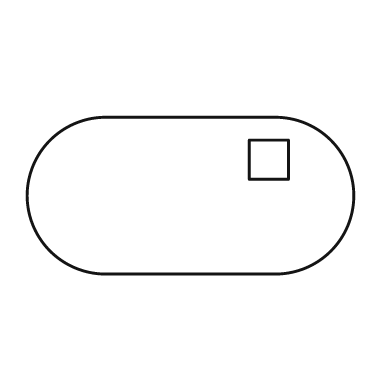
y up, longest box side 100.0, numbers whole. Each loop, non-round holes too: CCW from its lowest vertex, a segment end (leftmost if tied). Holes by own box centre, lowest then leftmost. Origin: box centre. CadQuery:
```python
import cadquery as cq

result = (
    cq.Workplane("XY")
    .moveTo(-26.0, -24.0)
    .lineTo(26.0, -24.0)
    .threePointArc((50.0, 0.0), (26.0, 24.0))
    .lineTo(-26.0, 24.0)
    .threePointArc((-50.0, 0.0), (-26.0, -24.0))
    .close()
    .moveTo(18.0, 5.0)
    .lineTo(30.0, 5.0)
    .lineTo(30.0, 17.0)
    .lineTo(18.0, 17.0)
    .close()
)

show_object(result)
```